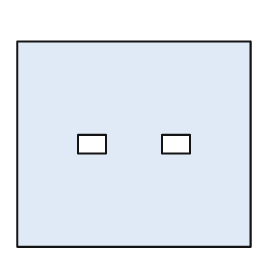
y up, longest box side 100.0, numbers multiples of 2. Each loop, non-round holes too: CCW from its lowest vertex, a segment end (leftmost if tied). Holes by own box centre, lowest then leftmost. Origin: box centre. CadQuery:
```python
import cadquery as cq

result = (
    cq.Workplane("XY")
    .moveTo(-50.0, -44.0)
    .lineTo(50.0, -44.0)
    .lineTo(50.0, 44.0)
    .lineTo(-50.0, 44.0)
    .close()
    .moveTo(-24.0, -4.0)
    .lineTo(-12.0, -4.0)
    .lineTo(-12.0, 4.0)
    .lineTo(-24.0, 4.0)
    .close()
    .moveTo(12.0, -4.0)
    .lineTo(24.0, -4.0)
    .lineTo(24.0, 4.0)
    .lineTo(12.0, 4.0)
    .close()
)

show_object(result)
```